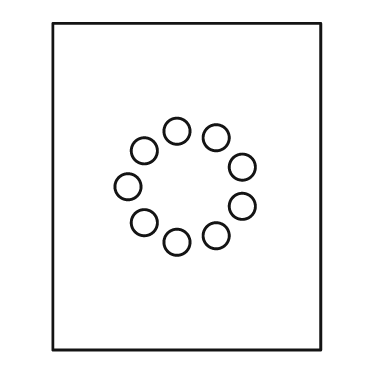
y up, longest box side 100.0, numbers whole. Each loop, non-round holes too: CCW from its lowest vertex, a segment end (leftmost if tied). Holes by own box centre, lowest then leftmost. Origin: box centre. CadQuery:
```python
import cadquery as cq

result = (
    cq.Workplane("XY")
    .moveTo(-41.0, -50.0)
    .lineTo(41.0, -50.0)
    .lineTo(41.0, 50.0)
    .lineTo(-41.0, 50.0)
    .close()
    .moveTo(-3.0, -17.0)
    .circle(4.0)
    .moveTo(9.0, -15.0)
    .circle(4.0)
    .moveTo(-13.0, -11.0)
    .circle(4.0)
    .moveTo(17.0, -6.0)
    .circle(4.0)
    .moveTo(-18.0, 0.0)
    .circle(4.0)
    .moveTo(17.0, 6.0)
    .circle(4.0)
    .moveTo(-13.0, 11.0)
    .circle(4.0)
    .moveTo(9.0, 15.0)
    .circle(4.0)
    .moveTo(-3.0, 17.0)
    .circle(4.0)
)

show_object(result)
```